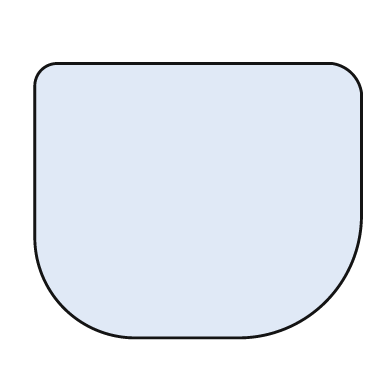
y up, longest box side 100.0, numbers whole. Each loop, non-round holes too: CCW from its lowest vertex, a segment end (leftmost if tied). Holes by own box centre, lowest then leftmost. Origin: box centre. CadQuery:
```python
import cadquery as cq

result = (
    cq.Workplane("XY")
    .moveTo(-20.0, -42.0)
    .lineTo(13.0, -42.0)
    .threePointArc((39.0, -31.0), (50.0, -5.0))
    .lineTo(50.0, 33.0)
    .threePointArc((47.0, 39.0), (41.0, 42.0))
    .lineTo(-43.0, 42.0)
    .threePointArc((-48.0, 40.0), (-50.0, 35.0))
    .lineTo(-50.0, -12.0)
    .threePointArc((-41.0, -33.0), (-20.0, -42.0))
    .close()
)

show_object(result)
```